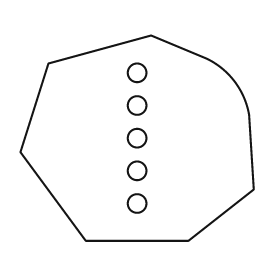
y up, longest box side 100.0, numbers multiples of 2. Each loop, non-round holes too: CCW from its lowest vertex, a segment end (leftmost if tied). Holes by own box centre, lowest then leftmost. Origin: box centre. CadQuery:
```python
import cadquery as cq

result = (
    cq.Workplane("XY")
    .moveTo(-22.0, -44.0)
    .lineTo(22.0, -44.0)
    .lineTo(50.0, -22.0)
    .lineTo(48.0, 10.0)
    .threePointArc((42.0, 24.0), (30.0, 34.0))
    .lineTo(6.0, 44.0)
    .lineTo(-38.0, 32.0)
    .lineTo(-50.0, -6.0)
    .close()
    .moveTo(0.0, -28.0)
    .circle(4.0)
    .moveTo(0.0, -14.0)
    .circle(4.0)
    .moveTo(0.0, 0.0)
    .circle(4.0)
    .moveTo(0.0, 14.0)
    .circle(4.0)
    .moveTo(0.0, 28.0)
    .circle(4.0)
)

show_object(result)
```